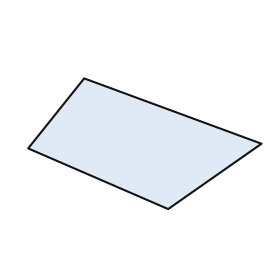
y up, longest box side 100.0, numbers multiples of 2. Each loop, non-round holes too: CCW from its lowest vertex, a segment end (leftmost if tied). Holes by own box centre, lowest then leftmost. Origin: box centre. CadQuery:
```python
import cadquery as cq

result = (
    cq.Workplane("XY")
    .moveTo(10.0, -28.0)
    .lineTo(50.0, 0.0)
    .lineTo(-26.0, 28.0)
    .lineTo(-50.0, -2.0)
    .close()
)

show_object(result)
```